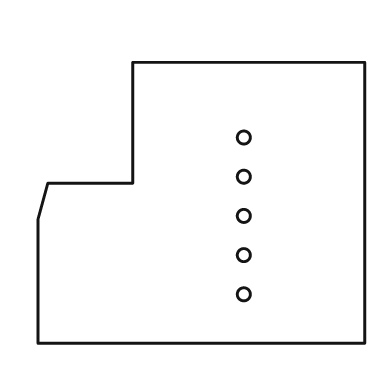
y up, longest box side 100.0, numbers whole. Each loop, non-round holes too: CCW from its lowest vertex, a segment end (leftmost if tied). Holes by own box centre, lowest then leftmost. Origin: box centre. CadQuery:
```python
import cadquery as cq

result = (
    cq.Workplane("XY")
    .moveTo(-50.0, -43.0)
    .lineTo(50.0, -43.0)
    .lineTo(50.0, 43.0)
    .lineTo(-21.0, 43.0)
    .lineTo(-21.0, 6.0)
    .lineTo(-47.0, 6.0)
    .lineTo(-50.0, -5.0)
    .close()
    .moveTo(13.0, -28.0)
    .circle(2.0)
    .moveTo(13.0, -16.0)
    .circle(2.0)
    .moveTo(13.0, -4.0)
    .circle(2.0)
    .moveTo(13.0, 8.0)
    .circle(2.0)
    .moveTo(13.0, 20.0)
    .circle(2.0)
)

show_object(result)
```